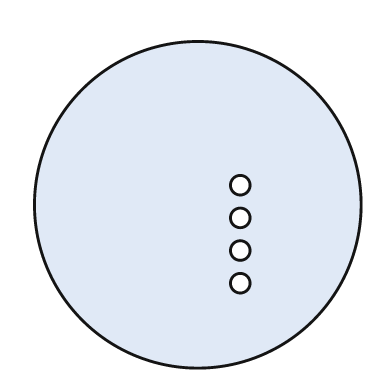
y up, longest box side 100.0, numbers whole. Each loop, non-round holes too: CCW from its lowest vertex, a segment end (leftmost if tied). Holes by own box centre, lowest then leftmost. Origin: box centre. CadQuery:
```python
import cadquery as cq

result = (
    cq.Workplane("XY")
    .moveTo(0.0, 0.0)
    .circle(50.0)
    .moveTo(13.0, -24.0)
    .circle(3.0)
    .moveTo(13.0, -14.0)
    .circle(3.0)
    .moveTo(13.0, -4.0)
    .circle(3.0)
    .moveTo(13.0, 6.0)
    .circle(3.0)
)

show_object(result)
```